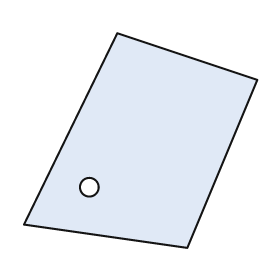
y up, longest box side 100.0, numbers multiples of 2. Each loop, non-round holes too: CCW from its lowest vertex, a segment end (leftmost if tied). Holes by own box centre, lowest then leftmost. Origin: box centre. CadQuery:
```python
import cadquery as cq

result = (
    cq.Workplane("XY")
    .moveTo(20.0, -46.0)
    .lineTo(50.0, 26.0)
    .lineTo(-10.0, 46.0)
    .lineTo(-50.0, -36.0)
    .close()
    .moveTo(-22.0, -20.0)
    .circle(4.0)
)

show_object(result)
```